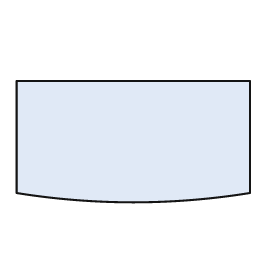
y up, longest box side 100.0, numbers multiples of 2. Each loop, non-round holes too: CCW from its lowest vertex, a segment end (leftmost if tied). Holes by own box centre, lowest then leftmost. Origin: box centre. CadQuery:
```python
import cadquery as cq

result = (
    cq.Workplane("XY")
    .moveTo(-50.0, -22.0)
    .threePointArc((0.0, -26.0), (50.0, -22.0))
    .lineTo(50.0, 26.0)
    .lineTo(-50.0, 26.0)
    .close()
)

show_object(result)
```